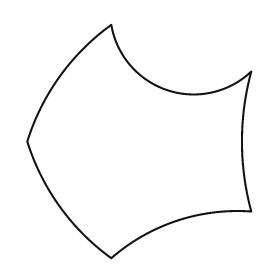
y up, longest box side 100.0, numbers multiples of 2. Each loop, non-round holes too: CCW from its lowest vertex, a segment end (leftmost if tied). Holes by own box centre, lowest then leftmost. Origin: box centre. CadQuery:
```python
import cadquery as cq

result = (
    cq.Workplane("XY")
    .moveTo(-12.0, -50.0)
    .threePointArc((16.0, -34.0), (48.0, -30.0))
    .threePointArc((44.0, 0.0), (48.0, 30.0))
    .threePointArc((12.0, 22.0), (-12.0, 50.0))
    .threePointArc((-34.0, 28.0), (-48.0, 0.0))
    .threePointArc((-34.0, -28.0), (-12.0, -50.0))
    .close()
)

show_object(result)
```